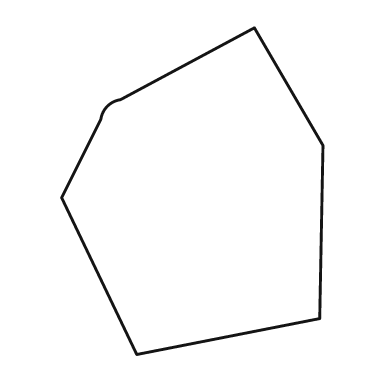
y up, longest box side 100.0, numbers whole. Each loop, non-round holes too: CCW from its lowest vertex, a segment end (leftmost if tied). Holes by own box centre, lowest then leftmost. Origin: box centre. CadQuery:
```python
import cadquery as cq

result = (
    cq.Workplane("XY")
    .moveTo(-17.0, -50.0)
    .lineTo(39.0, -39.0)
    .lineTo(40.0, 14.0)
    .lineTo(19.0, 50.0)
    .lineTo(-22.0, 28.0)
    .threePointArc((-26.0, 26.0), (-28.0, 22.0))
    .lineTo(-40.0, -2.0)
    .close()
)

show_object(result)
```